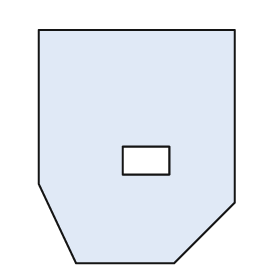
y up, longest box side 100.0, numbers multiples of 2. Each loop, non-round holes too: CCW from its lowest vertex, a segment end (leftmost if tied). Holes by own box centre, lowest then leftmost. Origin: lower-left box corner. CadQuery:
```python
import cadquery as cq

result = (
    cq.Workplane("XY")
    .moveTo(16.0, 0.0)
    .lineTo(58.0, 0.0)
    .lineTo(84.0, 26.0)
    .lineTo(84.0, 100.0)
    .lineTo(0.0, 100.0)
    .lineTo(0.0, 34.0)
    .close()
    .moveTo(36.0, 38.0)
    .lineTo(56.0, 38.0)
    .lineTo(56.0, 50.0)
    .lineTo(36.0, 50.0)
    .close()
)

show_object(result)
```